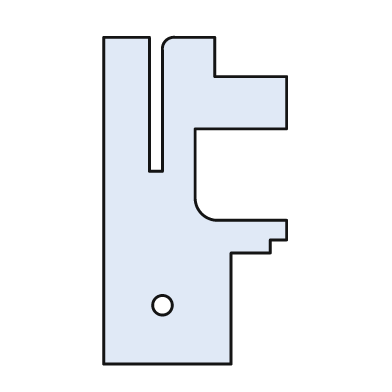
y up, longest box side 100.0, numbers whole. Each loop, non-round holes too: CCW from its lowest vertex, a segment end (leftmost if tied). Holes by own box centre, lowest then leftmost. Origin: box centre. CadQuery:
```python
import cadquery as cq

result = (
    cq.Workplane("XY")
    .moveTo(-28.0, -50.0)
    .lineTo(11.0, -50.0)
    .lineTo(11.0, -16.0)
    .lineTo(23.0, -16.0)
    .lineTo(23.0, -12.0)
    .lineTo(28.0, -12.0)
    .lineTo(28.0, -6.0)
    .lineTo(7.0, -6.0)
    .threePointArc((2.0, -4.0), (0.0, 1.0))
    .lineTo(0.0, 22.0)
    .lineTo(28.0, 22.0)
    .lineTo(28.0, 38.0)
    .lineTo(6.0, 38.0)
    .lineTo(6.0, 50.0)
    .lineTo(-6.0, 50.0)
    .threePointArc((-9.0, 49.0), (-10.0, 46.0))
    .lineTo(-10.0, 9.0)
    .lineTo(-14.0, 9.0)
    .lineTo(-14.0, 50.0)
    .lineTo(-28.0, 50.0)
    .close()
    .moveTo(-10.0, -32.0)
    .circle(3.0)
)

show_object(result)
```